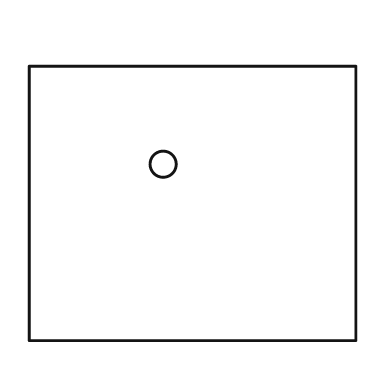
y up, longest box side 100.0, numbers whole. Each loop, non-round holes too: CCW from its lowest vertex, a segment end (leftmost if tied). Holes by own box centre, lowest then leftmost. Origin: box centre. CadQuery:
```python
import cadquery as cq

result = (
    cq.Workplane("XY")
    .moveTo(-50.0, -42.0)
    .lineTo(50.0, -42.0)
    .lineTo(50.0, 42.0)
    .lineTo(-50.0, 42.0)
    .close()
    .moveTo(-9.0, 12.0)
    .circle(4.0)
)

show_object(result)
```